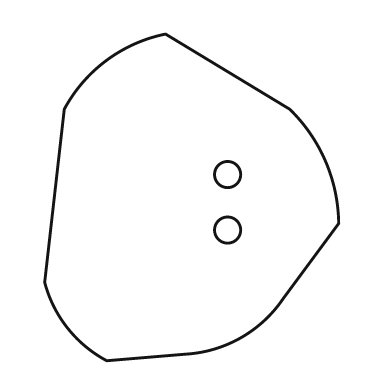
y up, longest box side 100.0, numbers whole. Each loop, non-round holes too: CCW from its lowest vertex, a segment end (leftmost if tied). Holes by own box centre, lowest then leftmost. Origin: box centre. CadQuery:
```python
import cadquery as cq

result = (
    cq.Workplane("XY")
    .moveTo(-26.0, -50.0)
    .lineTo(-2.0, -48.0)
    .threePointArc((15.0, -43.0), (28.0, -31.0))
    .lineTo(45.0, -8.0)
    .threePointArc((41.0, 11.0), (30.0, 27.0))
    .lineTo(-8.0, 50.0)
    .threePointArc((-26.0, 42.0), (-39.0, 27.0))
    .lineTo(-45.0, -26.0)
    .threePointArc((-38.0, -40.0), (-26.0, -50.0))
    .close()
    .moveTo(11.0, -10.0)
    .circle(4.0)
    .moveTo(11.0, 7.0)
    .circle(4.0)
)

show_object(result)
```